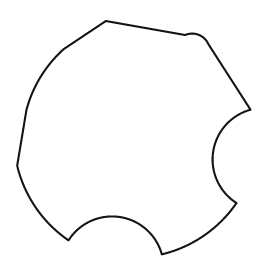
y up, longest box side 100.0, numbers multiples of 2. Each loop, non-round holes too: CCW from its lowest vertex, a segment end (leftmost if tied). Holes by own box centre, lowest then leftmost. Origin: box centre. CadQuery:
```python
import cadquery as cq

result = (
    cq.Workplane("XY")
    .moveTo(12.0, -50.0)
    .threePointArc((30.0, -42.0), (44.0, -28.0))
    .threePointArc((34.0, -6.0), (50.0, 12.0))
    .lineTo(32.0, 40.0)
    .threePointArc((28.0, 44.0), (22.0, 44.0))
    .lineTo(-12.0, 50.0)
    .lineTo(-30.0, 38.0)
    .threePointArc((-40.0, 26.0), (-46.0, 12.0))
    .lineTo(-50.0, -12.0)
    .threePointArc((-42.0, -30.0), (-28.0, -44.0))
    .threePointArc((-6.0, -34.0), (12.0, -50.0))
    .close()
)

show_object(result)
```